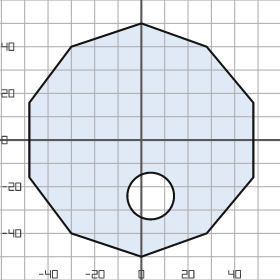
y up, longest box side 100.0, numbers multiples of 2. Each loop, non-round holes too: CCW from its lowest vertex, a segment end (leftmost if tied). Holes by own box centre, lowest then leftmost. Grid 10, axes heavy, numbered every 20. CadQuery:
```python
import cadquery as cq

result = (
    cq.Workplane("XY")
    .moveTo(0.0, -50.0)
    .lineTo(28.0, -40.0)
    .lineTo(48.0, -16.0)
    .lineTo(48.0, 16.0)
    .lineTo(28.0, 40.0)
    .lineTo(0.0, 50.0)
    .lineTo(-30.0, 40.0)
    .lineTo(-48.0, 16.0)
    .lineTo(-48.0, -16.0)
    .lineTo(-30.0, -40.0)
    .close()
    .moveTo(4.0, -24.0)
    .circle(10.0)
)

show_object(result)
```